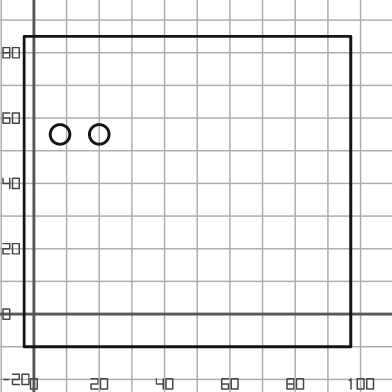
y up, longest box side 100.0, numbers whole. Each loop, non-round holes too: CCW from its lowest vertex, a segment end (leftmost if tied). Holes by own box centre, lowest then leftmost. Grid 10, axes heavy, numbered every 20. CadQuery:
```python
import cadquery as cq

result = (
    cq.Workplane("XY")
    .moveTo(-3.0, -10.0)
    .lineTo(97.0, -10.0)
    .lineTo(97.0, 85.0)
    .lineTo(-3.0, 85.0)
    .close()
    .moveTo(8.0, 55.0)
    .circle(3.0)
    .moveTo(20.0, 55.0)
    .circle(3.0)
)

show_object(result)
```